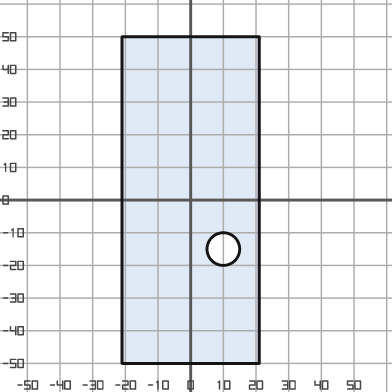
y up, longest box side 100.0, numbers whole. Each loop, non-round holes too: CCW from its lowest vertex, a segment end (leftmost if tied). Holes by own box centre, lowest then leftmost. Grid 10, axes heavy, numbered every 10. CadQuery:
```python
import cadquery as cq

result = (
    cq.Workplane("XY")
    .moveTo(-21.0, -50.0)
    .lineTo(21.0, -50.0)
    .lineTo(21.0, 50.0)
    .lineTo(-21.0, 50.0)
    .close()
    .moveTo(10.0, -15.0)
    .circle(5.0)
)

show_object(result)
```